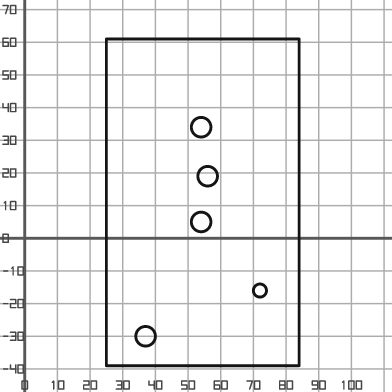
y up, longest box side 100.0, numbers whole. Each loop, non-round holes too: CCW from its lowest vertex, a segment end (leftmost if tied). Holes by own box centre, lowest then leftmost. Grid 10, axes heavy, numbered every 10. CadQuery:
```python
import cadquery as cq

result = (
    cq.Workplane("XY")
    .moveTo(25.0, -39.0)
    .lineTo(84.0, -39.0)
    .lineTo(84.0, 61.0)
    .lineTo(25.0, 61.0)
    .close()
    .moveTo(37.0, -30.0)
    .circle(3.0)
    .moveTo(72.0, -16.0)
    .circle(2.0)
    .moveTo(54.0, 5.0)
    .circle(3.0)
    .moveTo(56.0, 19.0)
    .circle(3.0)
    .moveTo(54.0, 34.0)
    .circle(3.0)
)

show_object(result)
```